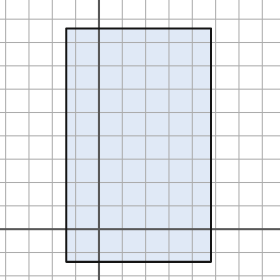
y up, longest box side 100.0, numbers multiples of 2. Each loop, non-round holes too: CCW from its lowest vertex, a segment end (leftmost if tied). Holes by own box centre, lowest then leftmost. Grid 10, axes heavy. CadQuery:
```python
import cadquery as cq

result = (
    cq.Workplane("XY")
    .moveTo(-14.0, -14.0)
    .lineTo(48.0, -14.0)
    .lineTo(48.0, 86.0)
    .lineTo(-14.0, 86.0)
    .close()
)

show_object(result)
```